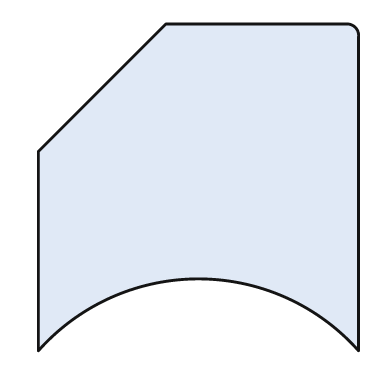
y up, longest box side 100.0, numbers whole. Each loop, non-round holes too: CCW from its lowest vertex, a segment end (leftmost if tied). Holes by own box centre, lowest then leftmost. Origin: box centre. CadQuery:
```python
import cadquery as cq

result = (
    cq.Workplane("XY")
    .moveTo(-49.0, -50.0)
    .threePointArc((0.0, -28.0), (49.0, -50.0))
    .lineTo(49.0, 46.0)
    .threePointArc((48.0, 49.0), (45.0, 50.0))
    .lineTo(-10.0, 50.0)
    .lineTo(-49.0, 11.0)
    .close()
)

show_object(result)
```